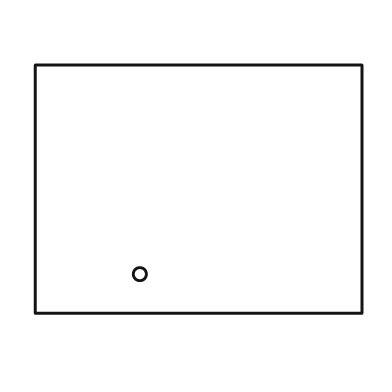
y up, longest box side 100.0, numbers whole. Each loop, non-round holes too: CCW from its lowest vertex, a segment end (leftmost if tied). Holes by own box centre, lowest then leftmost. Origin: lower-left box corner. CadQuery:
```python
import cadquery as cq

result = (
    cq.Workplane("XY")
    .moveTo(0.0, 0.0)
    .lineTo(100.0, 0.0)
    .lineTo(100.0, 76.0)
    .lineTo(0.0, 76.0)
    .close()
    .moveTo(32.0, 12.0)
    .circle(2.0)
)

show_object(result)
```